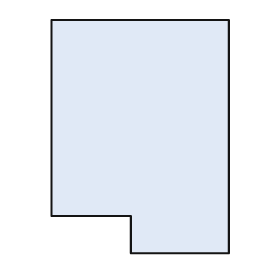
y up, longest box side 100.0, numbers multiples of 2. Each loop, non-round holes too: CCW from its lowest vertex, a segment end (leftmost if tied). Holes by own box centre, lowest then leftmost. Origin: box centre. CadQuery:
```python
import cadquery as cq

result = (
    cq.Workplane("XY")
    .moveTo(-4.0, -50.0)
    .lineTo(38.0, -50.0)
    .lineTo(38.0, 50.0)
    .lineTo(-38.0, 50.0)
    .lineTo(-38.0, -34.0)
    .lineTo(-4.0, -34.0)
    .close()
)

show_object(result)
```